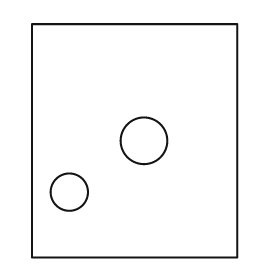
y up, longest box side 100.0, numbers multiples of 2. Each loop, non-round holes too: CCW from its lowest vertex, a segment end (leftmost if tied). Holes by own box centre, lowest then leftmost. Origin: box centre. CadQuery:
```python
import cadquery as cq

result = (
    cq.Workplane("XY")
    .moveTo(-44.0, -50.0)
    .lineTo(44.0, -50.0)
    .lineTo(44.0, 50.0)
    .lineTo(-44.0, 50.0)
    .close()
    .moveTo(-28.0, -22.0)
    .circle(8.0)
    .moveTo(4.0, 0.0)
    .circle(10.0)
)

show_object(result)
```